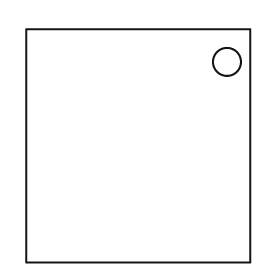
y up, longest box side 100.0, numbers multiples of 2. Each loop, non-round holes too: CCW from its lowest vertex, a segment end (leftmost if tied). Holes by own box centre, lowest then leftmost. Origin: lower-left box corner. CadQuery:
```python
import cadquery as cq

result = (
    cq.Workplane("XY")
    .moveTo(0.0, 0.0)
    .lineTo(96.0, 0.0)
    .lineTo(96.0, 100.0)
    .lineTo(0.0, 100.0)
    .close()
    .moveTo(86.0, 86.0)
    .circle(6.0)
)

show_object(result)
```